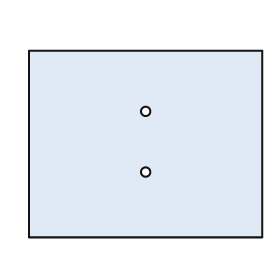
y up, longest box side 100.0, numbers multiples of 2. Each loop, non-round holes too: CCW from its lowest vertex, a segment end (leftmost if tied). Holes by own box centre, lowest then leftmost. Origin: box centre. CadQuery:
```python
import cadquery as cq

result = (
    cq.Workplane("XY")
    .moveTo(-50.0, -40.0)
    .lineTo(50.0, -40.0)
    .lineTo(50.0, 40.0)
    .lineTo(-50.0, 40.0)
    .close()
    .moveTo(0.0, -12.0)
    .circle(2.0)
    .moveTo(0.0, 14.0)
    .circle(2.0)
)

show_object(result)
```